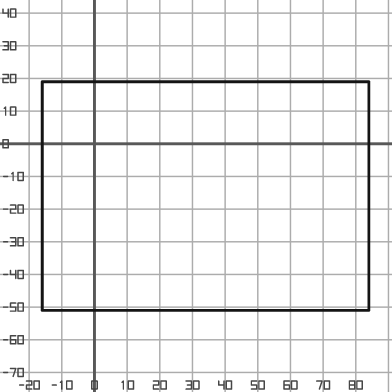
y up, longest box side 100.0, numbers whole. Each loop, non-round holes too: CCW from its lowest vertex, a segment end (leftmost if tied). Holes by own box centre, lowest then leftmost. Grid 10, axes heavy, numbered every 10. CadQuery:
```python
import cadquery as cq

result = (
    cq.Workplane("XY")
    .moveTo(-16.0, -51.0)
    .lineTo(84.0, -51.0)
    .lineTo(84.0, 19.0)
    .lineTo(-16.0, 19.0)
    .close()
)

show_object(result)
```